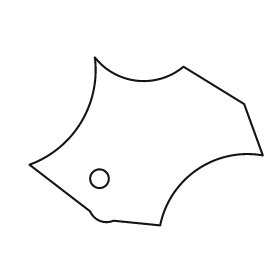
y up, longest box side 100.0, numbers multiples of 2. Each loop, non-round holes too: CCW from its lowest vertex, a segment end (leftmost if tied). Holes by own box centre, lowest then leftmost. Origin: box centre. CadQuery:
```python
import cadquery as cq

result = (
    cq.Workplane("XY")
    .moveTo(6.0, -36.0)
    .threePointArc((22.0, -12.0), (50.0, -6.0))
    .lineTo(42.0, 16.0)
    .lineTo(16.0, 32.0)
    .threePointArc((-4.0, 26.0), (-22.0, 36.0))
    .threePointArc((-28.0, 8.0), (-50.0, -10.0))
    .lineTo(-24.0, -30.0)
    .threePointArc((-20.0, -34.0), (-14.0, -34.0))
    .close()
    .moveTo(-20.0, -16.0)
    .circle(4.0)
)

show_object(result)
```